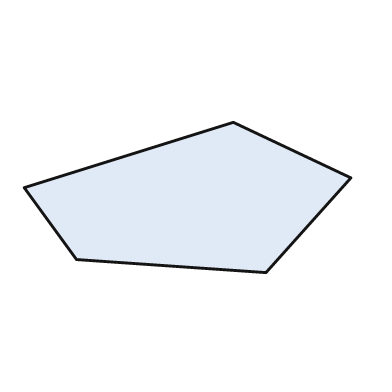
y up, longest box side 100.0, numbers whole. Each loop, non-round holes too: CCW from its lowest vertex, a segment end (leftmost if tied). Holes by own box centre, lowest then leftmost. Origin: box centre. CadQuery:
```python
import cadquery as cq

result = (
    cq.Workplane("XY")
    .moveTo(24.0, -23.0)
    .lineTo(50.0, 6.0)
    .lineTo(14.0, 23.0)
    .lineTo(-50.0, 3.0)
    .lineTo(-34.0, -19.0)
    .close()
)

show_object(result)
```